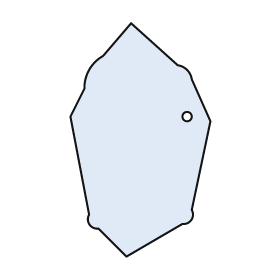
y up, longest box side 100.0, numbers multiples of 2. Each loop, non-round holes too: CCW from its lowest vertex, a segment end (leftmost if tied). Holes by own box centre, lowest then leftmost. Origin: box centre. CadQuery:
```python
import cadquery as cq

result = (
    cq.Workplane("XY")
    .moveTo(-6.0, -50.0)
    .lineTo(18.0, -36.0)
    .threePointArc((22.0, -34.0), (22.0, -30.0))
    .lineTo(30.0, 8.0)
    .lineTo(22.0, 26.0)
    .threePointArc((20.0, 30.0), (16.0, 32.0))
    .lineTo(-4.0, 50.0)
    .lineTo(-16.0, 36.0)
    .threePointArc((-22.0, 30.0), (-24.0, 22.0))
    .lineTo(-30.0, 10.0)
    .lineTo(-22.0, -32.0)
    .threePointArc((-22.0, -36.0), (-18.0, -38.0))
    .close()
    .moveTo(20.0, 10.0)
    .circle(2.0)
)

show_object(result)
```